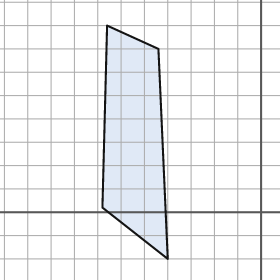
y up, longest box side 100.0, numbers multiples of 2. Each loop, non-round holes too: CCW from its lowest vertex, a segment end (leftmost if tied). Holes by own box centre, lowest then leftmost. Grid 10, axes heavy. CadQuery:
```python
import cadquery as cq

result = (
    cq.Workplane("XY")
    .moveTo(-40.0, -20.0)
    .lineTo(-44.0, 70.0)
    .lineTo(-66.0, 80.0)
    .lineTo(-68.0, 2.0)
    .close()
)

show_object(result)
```